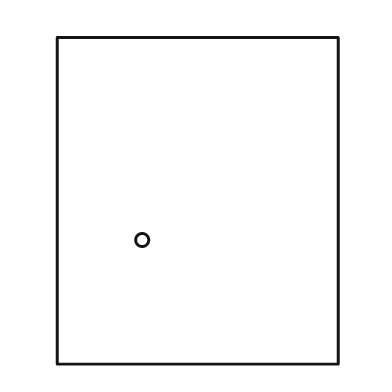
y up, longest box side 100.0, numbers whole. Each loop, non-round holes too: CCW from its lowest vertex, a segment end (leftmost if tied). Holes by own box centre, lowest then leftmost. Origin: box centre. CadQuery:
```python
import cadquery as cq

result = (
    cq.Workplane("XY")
    .moveTo(-43.0, -50.0)
    .lineTo(43.0, -50.0)
    .lineTo(43.0, 50.0)
    .lineTo(-43.0, 50.0)
    .close()
    .moveTo(-17.0, -12.0)
    .circle(2.0)
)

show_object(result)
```